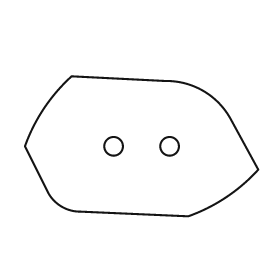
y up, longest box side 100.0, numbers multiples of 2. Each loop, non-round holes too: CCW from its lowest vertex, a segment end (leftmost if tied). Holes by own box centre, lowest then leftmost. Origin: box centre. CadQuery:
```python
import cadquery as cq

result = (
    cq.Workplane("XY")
    .moveTo(20.0, -30.0)
    .threePointArc((36.0, -22.0), (50.0, -10.0))
    .lineTo(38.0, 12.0)
    .threePointArc((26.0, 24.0), (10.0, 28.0))
    .lineTo(-30.0, 30.0)
    .threePointArc((-42.0, 16.0), (-50.0, 0.0))
    .lineTo(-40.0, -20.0)
    .threePointArc((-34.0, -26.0), (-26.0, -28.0))
    .close()
    .moveTo(-12.0, 0.0)
    .circle(4.0)
    .moveTo(12.0, 0.0)
    .circle(4.0)
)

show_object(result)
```